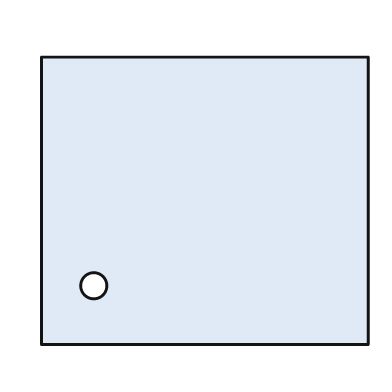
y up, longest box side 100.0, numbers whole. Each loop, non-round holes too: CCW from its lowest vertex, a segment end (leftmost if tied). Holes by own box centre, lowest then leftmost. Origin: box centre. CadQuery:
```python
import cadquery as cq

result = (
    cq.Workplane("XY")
    .moveTo(-50.0, -44.0)
    .lineTo(50.0, -44.0)
    .lineTo(50.0, 44.0)
    .lineTo(-50.0, 44.0)
    .close()
    .moveTo(-34.0, -26.0)
    .circle(4.0)
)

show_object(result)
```